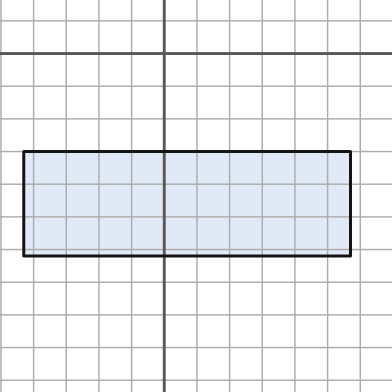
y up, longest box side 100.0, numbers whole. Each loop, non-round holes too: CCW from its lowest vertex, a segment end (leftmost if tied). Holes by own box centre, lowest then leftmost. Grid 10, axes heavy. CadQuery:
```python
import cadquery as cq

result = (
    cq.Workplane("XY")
    .moveTo(-43.0, -62.0)
    .lineTo(57.0, -62.0)
    .lineTo(57.0, -30.0)
    .lineTo(-43.0, -30.0)
    .close()
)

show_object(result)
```